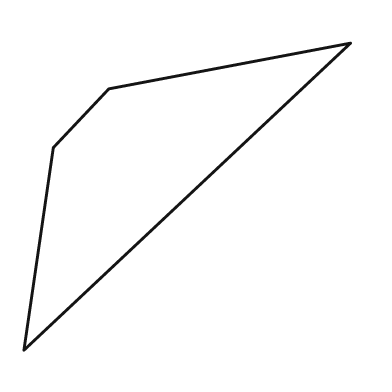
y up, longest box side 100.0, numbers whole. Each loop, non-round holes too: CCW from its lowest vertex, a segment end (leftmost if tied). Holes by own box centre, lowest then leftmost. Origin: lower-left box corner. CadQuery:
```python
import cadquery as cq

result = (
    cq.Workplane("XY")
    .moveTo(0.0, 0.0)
    .lineTo(100.0, 94.0)
    .lineTo(26.0, 80.0)
    .lineTo(9.0, 62.0)
    .close()
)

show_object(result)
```